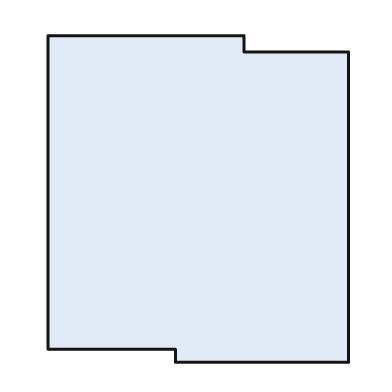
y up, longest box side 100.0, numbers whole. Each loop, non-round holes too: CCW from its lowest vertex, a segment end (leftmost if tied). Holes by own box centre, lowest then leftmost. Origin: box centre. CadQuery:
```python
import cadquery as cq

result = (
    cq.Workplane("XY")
    .moveTo(-7.0, -50.0)
    .lineTo(46.0, -50.0)
    .lineTo(46.0, 45.0)
    .lineTo(14.0, 45.0)
    .lineTo(14.0, 50.0)
    .lineTo(-46.0, 50.0)
    .lineTo(-46.0, -46.0)
    .lineTo(-7.0, -46.0)
    .close()
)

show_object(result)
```